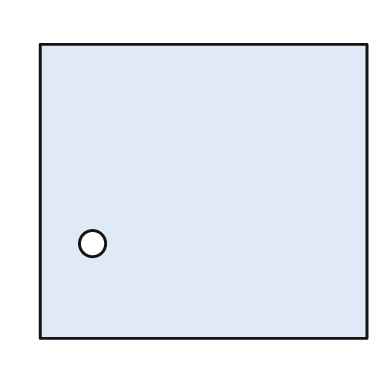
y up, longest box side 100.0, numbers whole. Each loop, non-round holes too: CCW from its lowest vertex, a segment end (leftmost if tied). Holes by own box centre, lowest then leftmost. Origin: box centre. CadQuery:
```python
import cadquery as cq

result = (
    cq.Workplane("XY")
    .moveTo(-50.0, -45.0)
    .lineTo(50.0, -45.0)
    .lineTo(50.0, 45.0)
    .lineTo(-50.0, 45.0)
    .close()
    .moveTo(-34.0, -16.0)
    .circle(4.0)
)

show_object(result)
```